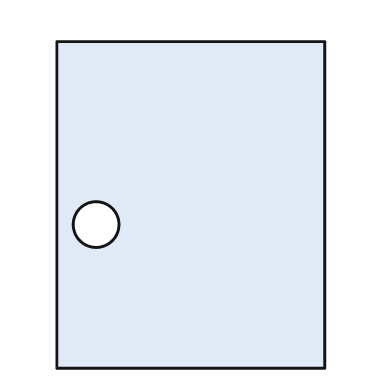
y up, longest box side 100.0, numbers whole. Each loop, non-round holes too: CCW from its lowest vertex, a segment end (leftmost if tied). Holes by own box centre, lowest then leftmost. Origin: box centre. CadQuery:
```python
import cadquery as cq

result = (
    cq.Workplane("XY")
    .moveTo(-41.0, -50.0)
    .lineTo(41.0, -50.0)
    .lineTo(41.0, 50.0)
    .lineTo(-41.0, 50.0)
    .close()
    .moveTo(-29.0, -6.0)
    .circle(7.0)
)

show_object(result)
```